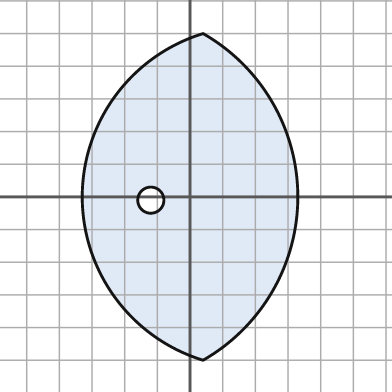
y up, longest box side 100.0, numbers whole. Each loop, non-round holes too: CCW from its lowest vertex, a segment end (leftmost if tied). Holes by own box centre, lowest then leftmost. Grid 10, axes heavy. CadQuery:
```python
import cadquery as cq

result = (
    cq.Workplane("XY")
    .moveTo(4.0, -50.0)
    .threePointArc((33.0, 0.0), (4.0, 50.0))
    .threePointArc((-33.0, 0.0), (4.0, -50.0))
    .close()
    .moveTo(-12.0, -1.0)
    .circle(4.0)
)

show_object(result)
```